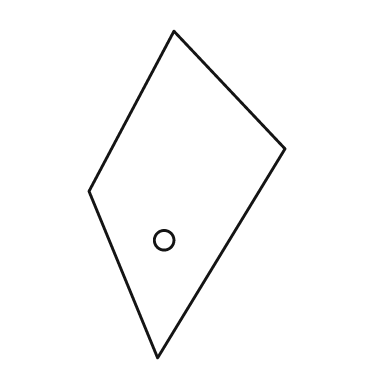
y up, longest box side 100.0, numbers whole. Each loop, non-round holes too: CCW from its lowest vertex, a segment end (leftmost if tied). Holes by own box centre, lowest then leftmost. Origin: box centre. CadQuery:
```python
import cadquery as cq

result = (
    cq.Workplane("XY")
    .moveTo(-9.0, -50.0)
    .lineTo(30.0, 14.0)
    .lineTo(-4.0, 50.0)
    .lineTo(-30.0, 1.0)
    .close()
    .moveTo(-7.0, -14.0)
    .circle(3.0)
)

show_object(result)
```